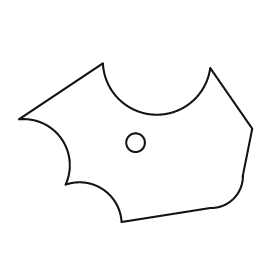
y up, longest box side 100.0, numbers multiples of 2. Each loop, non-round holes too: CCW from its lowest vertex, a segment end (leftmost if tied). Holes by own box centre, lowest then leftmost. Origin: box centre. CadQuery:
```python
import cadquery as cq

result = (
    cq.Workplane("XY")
    .moveTo(-6.0, -34.0)
    .lineTo(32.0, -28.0)
    .threePointArc((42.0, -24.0), (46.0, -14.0))
    .lineTo(50.0, 6.0)
    .lineTo(32.0, 32.0)
    .threePointArc((8.0, 12.0), (-14.0, 34.0))
    .lineTo(-50.0, 10.0)
    .threePointArc((-32.0, 2.0), (-30.0, -18.0))
    .threePointArc((-14.0, -20.0), (-6.0, -34.0))
    .close()
    .moveTo(0.0, 0.0)
    .circle(4.0)
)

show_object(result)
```